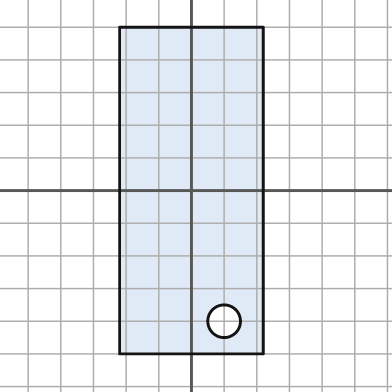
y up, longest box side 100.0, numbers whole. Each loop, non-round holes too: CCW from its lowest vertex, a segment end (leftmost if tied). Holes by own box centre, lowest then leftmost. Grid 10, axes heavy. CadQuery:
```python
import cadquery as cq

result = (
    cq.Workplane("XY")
    .moveTo(-22.0, -50.0)
    .lineTo(22.0, -50.0)
    .lineTo(22.0, 50.0)
    .lineTo(-22.0, 50.0)
    .close()
    .moveTo(10.0, -40.0)
    .circle(5.0)
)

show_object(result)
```